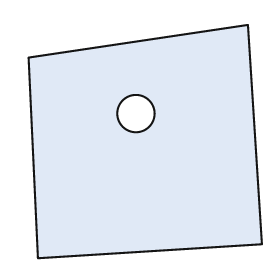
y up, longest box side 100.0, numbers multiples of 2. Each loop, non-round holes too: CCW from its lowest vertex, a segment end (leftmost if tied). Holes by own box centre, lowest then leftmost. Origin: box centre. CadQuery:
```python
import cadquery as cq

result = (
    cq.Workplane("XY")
    .moveTo(-46.0, -50.0)
    .lineTo(50.0, -44.0)
    .lineTo(44.0, 50.0)
    .lineTo(-50.0, 36.0)
    .close()
    .moveTo(-4.0, 12.0)
    .circle(8.0)
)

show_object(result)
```